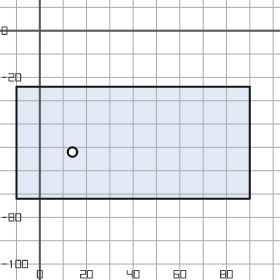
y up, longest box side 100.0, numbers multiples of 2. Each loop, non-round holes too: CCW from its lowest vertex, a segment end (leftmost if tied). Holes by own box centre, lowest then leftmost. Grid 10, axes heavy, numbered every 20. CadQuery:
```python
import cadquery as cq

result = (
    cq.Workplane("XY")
    .moveTo(-10.0, -72.0)
    .lineTo(90.0, -72.0)
    .lineTo(90.0, -24.0)
    .lineTo(-10.0, -24.0)
    .close()
    .moveTo(14.0, -52.0)
    .circle(2.0)
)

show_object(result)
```